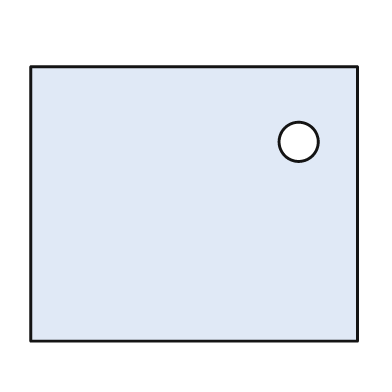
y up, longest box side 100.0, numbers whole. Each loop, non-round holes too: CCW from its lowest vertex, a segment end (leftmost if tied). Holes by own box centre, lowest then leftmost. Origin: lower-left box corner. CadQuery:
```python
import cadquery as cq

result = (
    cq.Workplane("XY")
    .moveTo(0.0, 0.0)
    .lineTo(100.0, 0.0)
    .lineTo(100.0, 84.0)
    .lineTo(0.0, 84.0)
    .close()
    .moveTo(82.0, 61.0)
    .circle(6.0)
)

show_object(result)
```